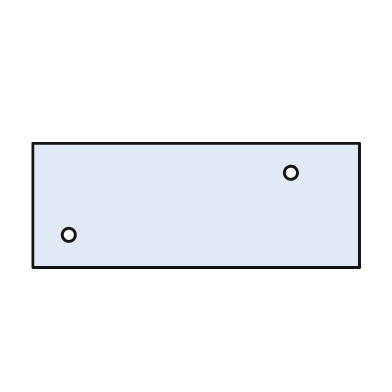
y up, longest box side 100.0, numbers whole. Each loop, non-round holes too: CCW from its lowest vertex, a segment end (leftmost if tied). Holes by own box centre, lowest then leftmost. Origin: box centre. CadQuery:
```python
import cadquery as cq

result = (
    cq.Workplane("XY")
    .moveTo(-50.0, -19.0)
    .lineTo(50.0, -19.0)
    .lineTo(50.0, 19.0)
    .lineTo(-50.0, 19.0)
    .close()
    .moveTo(-39.0, -9.0)
    .circle(2.0)
    .moveTo(29.0, 10.0)
    .circle(2.0)
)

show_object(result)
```